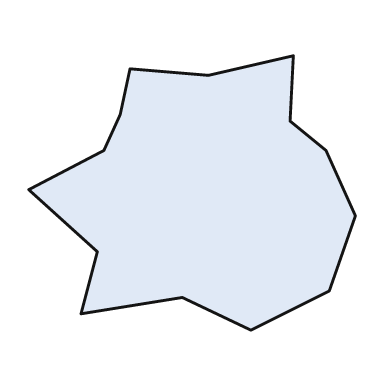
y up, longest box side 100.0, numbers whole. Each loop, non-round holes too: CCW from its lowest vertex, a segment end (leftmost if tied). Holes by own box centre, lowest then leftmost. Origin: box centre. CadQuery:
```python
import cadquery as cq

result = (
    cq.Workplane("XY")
    .moveTo(18.0, -42.0)
    .lineTo(42.0, -30.0)
    .lineTo(50.0, -7.0)
    .lineTo(41.0, 13.0)
    .lineTo(30.0, 22.0)
    .lineTo(31.0, 42.0)
    .lineTo(5.0, 36.0)
    .lineTo(-19.0, 38.0)
    .lineTo(-22.0, 24.0)
    .lineTo(-27.0, 13.0)
    .lineTo(-50.0, 1.0)
    .lineTo(-29.0, -18.0)
    .lineTo(-34.0, -37.0)
    .lineTo(-3.0, -32.0)
    .close()
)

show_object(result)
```